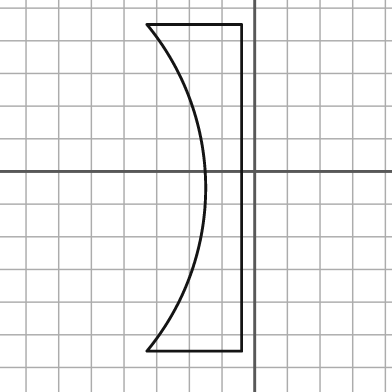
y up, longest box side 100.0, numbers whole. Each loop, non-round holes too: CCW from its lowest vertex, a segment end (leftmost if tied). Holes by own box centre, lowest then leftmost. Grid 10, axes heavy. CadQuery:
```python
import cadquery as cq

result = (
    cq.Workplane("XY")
    .moveTo(-33.0, -55.0)
    .lineTo(-4.0, -55.0)
    .lineTo(-4.0, 45.0)
    .lineTo(-33.0, 45.0)
    .threePointArc((-15.0, -5.0), (-33.0, -55.0))
    .close()
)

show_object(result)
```